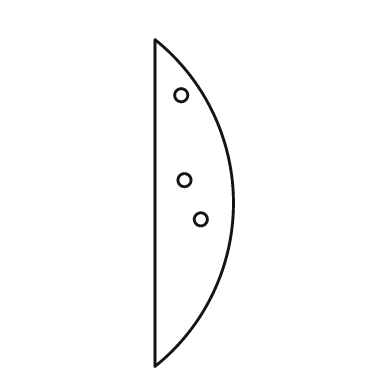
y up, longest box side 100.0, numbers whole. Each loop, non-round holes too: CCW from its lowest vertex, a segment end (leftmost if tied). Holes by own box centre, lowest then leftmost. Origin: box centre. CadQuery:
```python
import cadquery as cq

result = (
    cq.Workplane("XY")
    .moveTo(-12.0, -50.0)
    .threePointArc((12.0, 0.0), (-12.0, 50.0))
    .close()
    .moveTo(2.0, -5.0)
    .circle(2.0)
    .moveTo(-3.0, 7.0)
    .circle(2.0)
    .moveTo(-4.0, 33.0)
    .circle(2.0)
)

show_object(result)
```